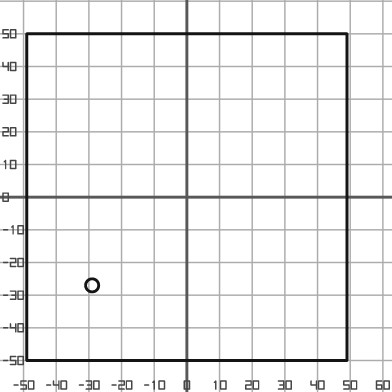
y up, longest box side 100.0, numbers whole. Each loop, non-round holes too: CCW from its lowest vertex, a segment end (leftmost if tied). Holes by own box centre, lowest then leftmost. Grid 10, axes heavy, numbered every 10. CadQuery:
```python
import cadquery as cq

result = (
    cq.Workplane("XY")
    .moveTo(-49.0, -50.0)
    .lineTo(49.0, -50.0)
    .lineTo(49.0, 50.0)
    .lineTo(-49.0, 50.0)
    .close()
    .moveTo(-29.0, -27.0)
    .circle(2.0)
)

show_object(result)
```